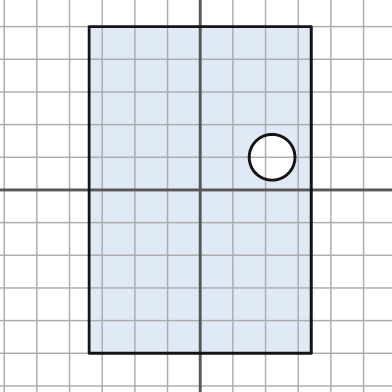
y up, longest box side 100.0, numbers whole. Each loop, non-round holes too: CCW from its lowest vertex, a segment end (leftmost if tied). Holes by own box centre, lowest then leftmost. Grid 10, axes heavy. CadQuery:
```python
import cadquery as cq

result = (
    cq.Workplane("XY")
    .moveTo(-34.0, -50.0)
    .lineTo(34.0, -50.0)
    .lineTo(34.0, 50.0)
    .lineTo(-34.0, 50.0)
    .close()
    .moveTo(22.0, 10.0)
    .circle(7.0)
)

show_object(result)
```